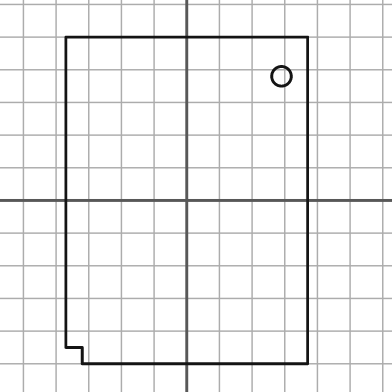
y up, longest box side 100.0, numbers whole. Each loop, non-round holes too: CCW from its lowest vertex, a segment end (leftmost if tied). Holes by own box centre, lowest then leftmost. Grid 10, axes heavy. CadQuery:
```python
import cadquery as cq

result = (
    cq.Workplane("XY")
    .moveTo(-32.0, -50.0)
    .lineTo(37.0, -50.0)
    .lineTo(37.0, 50.0)
    .lineTo(-37.0, 50.0)
    .lineTo(-37.0, -45.0)
    .lineTo(-32.0, -45.0)
    .close()
    .moveTo(29.0, 38.0)
    .circle(3.0)
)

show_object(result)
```